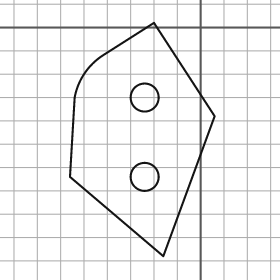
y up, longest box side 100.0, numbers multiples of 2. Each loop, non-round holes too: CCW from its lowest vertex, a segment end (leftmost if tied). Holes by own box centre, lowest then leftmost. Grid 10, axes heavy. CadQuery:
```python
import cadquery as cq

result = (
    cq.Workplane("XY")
    .moveTo(-16.0, -98.0)
    .lineTo(6.0, -38.0)
    .lineTo(-20.0, 2.0)
    .lineTo(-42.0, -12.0)
    .threePointArc((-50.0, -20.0), (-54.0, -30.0))
    .lineTo(-56.0, -64.0)
    .close()
    .moveTo(-24.0, -64.0)
    .circle(6.0)
    .moveTo(-24.0, -30.0)
    .circle(6.0)
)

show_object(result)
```